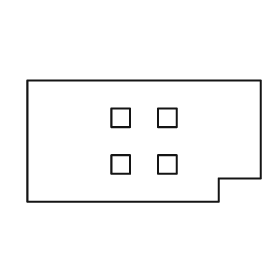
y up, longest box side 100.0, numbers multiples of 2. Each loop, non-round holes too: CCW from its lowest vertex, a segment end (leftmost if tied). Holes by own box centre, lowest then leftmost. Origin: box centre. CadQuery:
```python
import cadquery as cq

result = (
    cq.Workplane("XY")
    .moveTo(-50.0, -26.0)
    .lineTo(32.0, -26.0)
    .lineTo(32.0, -16.0)
    .lineTo(50.0, -16.0)
    .lineTo(50.0, 26.0)
    .lineTo(-50.0, 26.0)
    .close()
    .moveTo(-14.0, -14.0)
    .lineTo(-6.0, -14.0)
    .lineTo(-6.0, -6.0)
    .lineTo(-14.0, -6.0)
    .close()
    .moveTo(6.0, -14.0)
    .lineTo(14.0, -14.0)
    .lineTo(14.0, -6.0)
    .lineTo(6.0, -6.0)
    .close()
    .moveTo(-14.0, 6.0)
    .lineTo(-6.0, 6.0)
    .lineTo(-6.0, 14.0)
    .lineTo(-14.0, 14.0)
    .close()
    .moveTo(6.0, 6.0)
    .lineTo(14.0, 6.0)
    .lineTo(14.0, 14.0)
    .lineTo(6.0, 14.0)
    .close()
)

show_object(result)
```